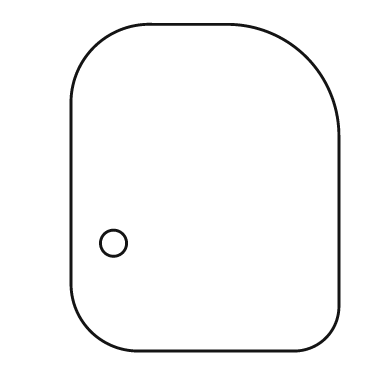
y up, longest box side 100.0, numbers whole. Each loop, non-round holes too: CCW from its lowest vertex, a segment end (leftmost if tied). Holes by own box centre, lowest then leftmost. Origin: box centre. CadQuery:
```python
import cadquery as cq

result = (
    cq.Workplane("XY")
    .moveTo(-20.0, -50.0)
    .lineTo(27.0, -50.0)
    .threePointArc((37.0, -46.0), (41.0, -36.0))
    .lineTo(41.0, 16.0)
    .threePointArc((31.0, 40.0), (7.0, 50.0))
    .lineTo(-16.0, 50.0)
    .threePointArc((-34.0, 43.0), (-41.0, 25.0))
    .lineTo(-41.0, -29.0)
    .threePointArc((-35.0, -44.0), (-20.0, -50.0))
    .close()
    .moveTo(-28.0, -17.0)
    .circle(4.0)
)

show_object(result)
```